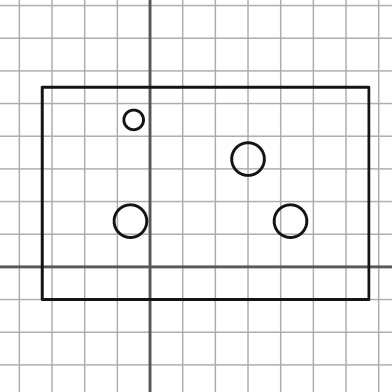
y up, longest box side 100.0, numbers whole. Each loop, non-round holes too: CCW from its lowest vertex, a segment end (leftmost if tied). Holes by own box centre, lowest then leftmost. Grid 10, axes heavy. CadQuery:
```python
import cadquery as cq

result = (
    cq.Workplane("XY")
    .moveTo(-33.0, -10.0)
    .lineTo(67.0, -10.0)
    .lineTo(67.0, 55.0)
    .lineTo(-33.0, 55.0)
    .close()
    .moveTo(-6.0, 14.0)
    .circle(5.0)
    .moveTo(43.0, 14.0)
    .circle(5.0)
    .moveTo(30.0, 33.0)
    .circle(5.0)
    .moveTo(-5.0, 45.0)
    .circle(3.0)
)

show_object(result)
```